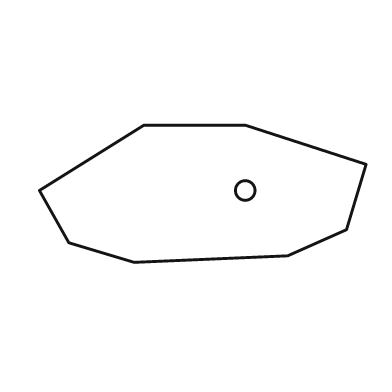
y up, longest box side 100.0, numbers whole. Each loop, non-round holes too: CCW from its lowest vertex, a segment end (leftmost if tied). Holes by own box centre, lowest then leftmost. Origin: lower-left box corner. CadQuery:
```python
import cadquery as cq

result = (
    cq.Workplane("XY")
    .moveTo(29.0, 0.0)
    .lineTo(76.0, 2.0)
    .lineTo(94.0, 10.0)
    .lineTo(100.0, 30.0)
    .lineTo(63.0, 42.0)
    .lineTo(32.0, 42.0)
    .lineTo(0.0, 22.0)
    .lineTo(9.0, 6.0)
    .close()
    .moveTo(63.0, 22.0)
    .circle(3.0)
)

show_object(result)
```